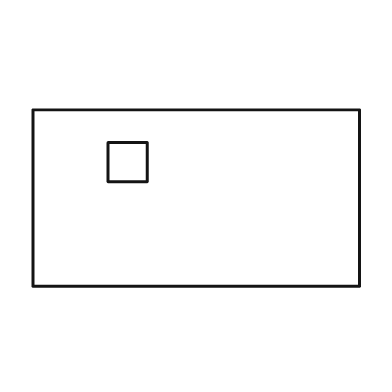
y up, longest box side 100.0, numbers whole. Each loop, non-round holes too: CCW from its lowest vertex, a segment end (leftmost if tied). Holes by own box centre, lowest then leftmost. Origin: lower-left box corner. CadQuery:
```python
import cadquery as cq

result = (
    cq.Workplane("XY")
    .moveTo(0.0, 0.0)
    .lineTo(100.0, 0.0)
    .lineTo(100.0, 54.0)
    .lineTo(0.0, 54.0)
    .close()
    .moveTo(23.0, 32.0)
    .lineTo(35.0, 32.0)
    .lineTo(35.0, 44.0)
    .lineTo(23.0, 44.0)
    .close()
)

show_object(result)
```